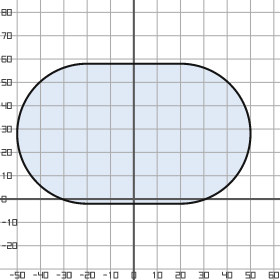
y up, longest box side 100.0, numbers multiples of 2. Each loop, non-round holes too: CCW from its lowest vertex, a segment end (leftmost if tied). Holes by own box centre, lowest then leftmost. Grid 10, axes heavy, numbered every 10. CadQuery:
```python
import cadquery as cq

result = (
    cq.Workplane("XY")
    .moveTo(-20.0, -2.0)
    .lineTo(20.0, -2.0)
    .threePointArc((50.0, 28.0), (20.0, 58.0))
    .lineTo(-20.0, 58.0)
    .threePointArc((-50.0, 28.0), (-20.0, -2.0))
    .close()
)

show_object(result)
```